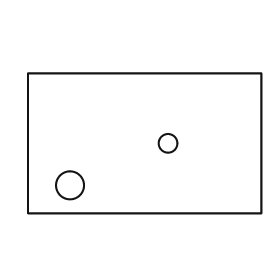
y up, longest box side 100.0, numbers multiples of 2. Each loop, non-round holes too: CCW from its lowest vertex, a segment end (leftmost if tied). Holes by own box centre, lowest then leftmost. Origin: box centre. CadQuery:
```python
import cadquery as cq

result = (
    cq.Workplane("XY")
    .moveTo(-50.0, -30.0)
    .lineTo(50.0, -30.0)
    .lineTo(50.0, 30.0)
    .lineTo(-50.0, 30.0)
    .close()
    .moveTo(-32.0, -18.0)
    .circle(6.0)
    .moveTo(10.0, 0.0)
    .circle(4.0)
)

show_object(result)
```